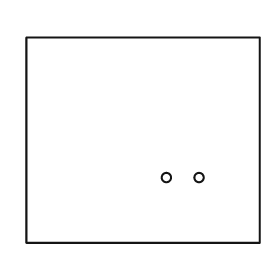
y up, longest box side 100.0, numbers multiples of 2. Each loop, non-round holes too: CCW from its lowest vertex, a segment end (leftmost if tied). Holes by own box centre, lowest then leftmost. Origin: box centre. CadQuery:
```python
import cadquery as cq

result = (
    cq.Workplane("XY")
    .moveTo(-50.0, -44.0)
    .lineTo(50.0, -44.0)
    .lineTo(50.0, 44.0)
    .lineTo(-50.0, 44.0)
    .close()
    .moveTo(10.0, -16.0)
    .circle(2.0)
    .moveTo(24.0, -16.0)
    .circle(2.0)
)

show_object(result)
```